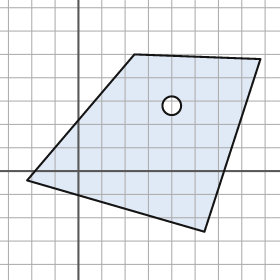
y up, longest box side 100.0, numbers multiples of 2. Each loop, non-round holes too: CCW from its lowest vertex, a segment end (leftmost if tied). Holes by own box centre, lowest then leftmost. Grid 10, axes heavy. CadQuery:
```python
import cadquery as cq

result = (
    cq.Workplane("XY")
    .moveTo(54.0, -26.0)
    .lineTo(78.0, 48.0)
    .lineTo(24.0, 50.0)
    .lineTo(-22.0, -4.0)
    .close()
    .moveTo(40.0, 28.0)
    .circle(4.0)
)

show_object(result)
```